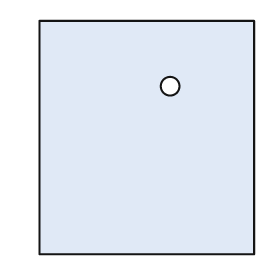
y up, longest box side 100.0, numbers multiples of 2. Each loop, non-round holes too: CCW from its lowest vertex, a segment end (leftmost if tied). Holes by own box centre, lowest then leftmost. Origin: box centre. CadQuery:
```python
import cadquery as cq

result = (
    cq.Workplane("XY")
    .moveTo(-46.0, -50.0)
    .lineTo(46.0, -50.0)
    .lineTo(46.0, 50.0)
    .lineTo(-46.0, 50.0)
    .close()
    .moveTo(10.0, 22.0)
    .circle(4.0)
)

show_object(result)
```